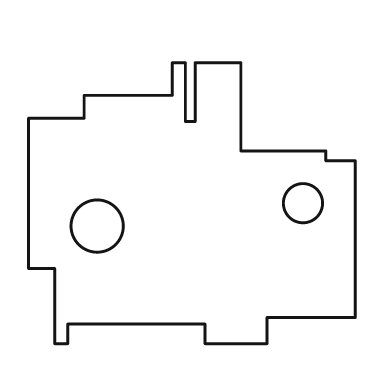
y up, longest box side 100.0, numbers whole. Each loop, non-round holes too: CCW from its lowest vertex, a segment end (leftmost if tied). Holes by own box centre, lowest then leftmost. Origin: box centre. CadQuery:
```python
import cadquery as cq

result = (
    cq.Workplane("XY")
    .moveTo(-42.0, -43.0)
    .lineTo(-38.0, -43.0)
    .lineTo(-38.0, -37.0)
    .lineTo(4.0, -37.0)
    .lineTo(4.0, -43.0)
    .lineTo(23.0, -43.0)
    .lineTo(23.0, -35.0)
    .lineTo(50.0, -35.0)
    .lineTo(50.0, 13.0)
    .lineTo(41.0, 13.0)
    .lineTo(41.0, 16.0)
    .lineTo(15.0, 16.0)
    .lineTo(15.0, 43.0)
    .lineTo(1.0, 43.0)
    .lineTo(1.0, 25.0)
    .lineTo(-2.0, 25.0)
    .lineTo(-2.0, 43.0)
    .lineTo(-6.0, 43.0)
    .lineTo(-6.0, 33.0)
    .lineTo(-33.0, 33.0)
    .lineTo(-33.0, 26.0)
    .lineTo(-50.0, 26.0)
    .lineTo(-50.0, -20.0)
    .lineTo(-42.0, -20.0)
    .close()
    .moveTo(-29.0, -7.0)
    .circle(8.0)
    .moveTo(34.0, 0.0)
    .circle(6.0)
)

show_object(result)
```